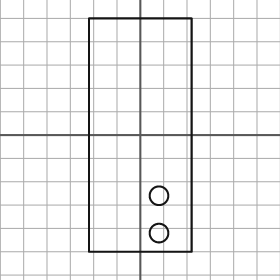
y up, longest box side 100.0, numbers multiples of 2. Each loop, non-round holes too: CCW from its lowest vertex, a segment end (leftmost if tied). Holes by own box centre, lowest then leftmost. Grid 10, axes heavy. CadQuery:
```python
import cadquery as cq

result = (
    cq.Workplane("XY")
    .moveTo(-22.0, -50.0)
    .lineTo(22.0, -50.0)
    .lineTo(22.0, 50.0)
    .lineTo(-22.0, 50.0)
    .close()
    .moveTo(8.0, -42.0)
    .circle(4.0)
    .moveTo(8.0, -26.0)
    .circle(4.0)
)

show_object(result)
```